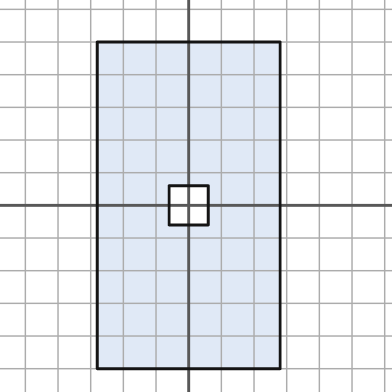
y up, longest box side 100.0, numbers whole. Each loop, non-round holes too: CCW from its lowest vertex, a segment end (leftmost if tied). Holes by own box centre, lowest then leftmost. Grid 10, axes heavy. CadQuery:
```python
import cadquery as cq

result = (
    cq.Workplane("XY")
    .moveTo(-28.0, -50.0)
    .lineTo(28.0, -50.0)
    .lineTo(28.0, 50.0)
    .lineTo(-28.0, 50.0)
    .close()
    .moveTo(-6.0, -6.0)
    .lineTo(6.0, -6.0)
    .lineTo(6.0, 6.0)
    .lineTo(-6.0, 6.0)
    .close()
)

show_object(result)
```